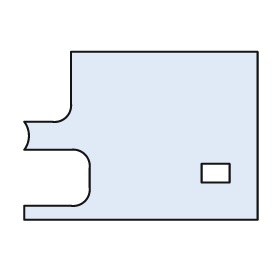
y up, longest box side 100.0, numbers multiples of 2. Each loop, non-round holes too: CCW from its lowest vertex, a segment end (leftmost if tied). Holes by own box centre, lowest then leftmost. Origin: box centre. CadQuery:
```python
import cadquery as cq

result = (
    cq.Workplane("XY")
    .moveTo(-50.0, -36.0)
    .lineTo(50.0, -36.0)
    .lineTo(50.0, 36.0)
    .lineTo(-30.0, 36.0)
    .lineTo(-30.0, 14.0)
    .threePointArc((-32.0, 8.0), (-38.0, 6.0))
    .lineTo(-50.0, 6.0)
    .threePointArc((-48.0, 0.0), (-50.0, -6.0))
    .lineTo(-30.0, -6.0)
    .threePointArc((-24.0, -8.0), (-22.0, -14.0))
    .lineTo(-22.0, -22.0)
    .threePointArc((-24.0, -28.0), (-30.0, -30.0))
    .lineTo(-50.0, -30.0)
    .close()
    .moveTo(26.0, -20.0)
    .lineTo(38.0, -20.0)
    .lineTo(38.0, -12.0)
    .lineTo(26.0, -12.0)
    .close()
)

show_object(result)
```